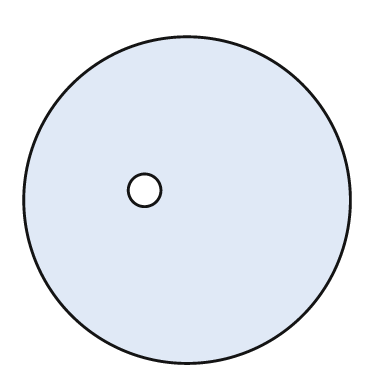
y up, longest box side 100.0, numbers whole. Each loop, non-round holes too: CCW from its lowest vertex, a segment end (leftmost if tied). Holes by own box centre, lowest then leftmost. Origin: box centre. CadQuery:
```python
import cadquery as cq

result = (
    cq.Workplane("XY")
    .moveTo(0.0, 0.0)
    .circle(50.0)
    .moveTo(-13.0, 3.0)
    .circle(5.0)
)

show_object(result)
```